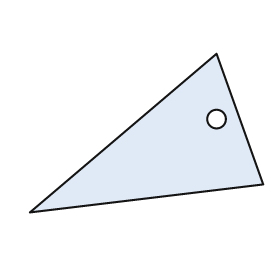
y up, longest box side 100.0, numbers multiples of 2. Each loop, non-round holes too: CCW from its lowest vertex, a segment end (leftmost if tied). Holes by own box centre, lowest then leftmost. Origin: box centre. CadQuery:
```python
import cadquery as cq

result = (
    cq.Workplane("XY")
    .moveTo(-50.0, -34.0)
    .lineTo(50.0, -22.0)
    .lineTo(30.0, 34.0)
    .close()
    .moveTo(30.0, 6.0)
    .circle(4.0)
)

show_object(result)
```